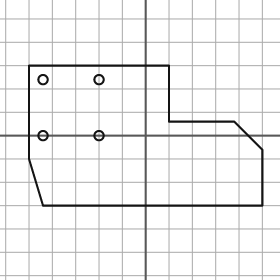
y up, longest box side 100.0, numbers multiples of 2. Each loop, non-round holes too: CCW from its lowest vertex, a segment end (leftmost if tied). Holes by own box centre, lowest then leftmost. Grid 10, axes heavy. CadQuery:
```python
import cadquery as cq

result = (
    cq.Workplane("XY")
    .moveTo(-44.0, -30.0)
    .lineTo(50.0, -30.0)
    .lineTo(50.0, -6.0)
    .lineTo(38.0, 6.0)
    .lineTo(10.0, 6.0)
    .lineTo(10.0, 30.0)
    .lineTo(-50.0, 30.0)
    .lineTo(-50.0, -10.0)
    .close()
    .moveTo(-44.0, 0.0)
    .circle(2.0)
    .moveTo(-20.0, 0.0)
    .circle(2.0)
    .moveTo(-44.0, 24.0)
    .circle(2.0)
    .moveTo(-20.0, 24.0)
    .circle(2.0)
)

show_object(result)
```